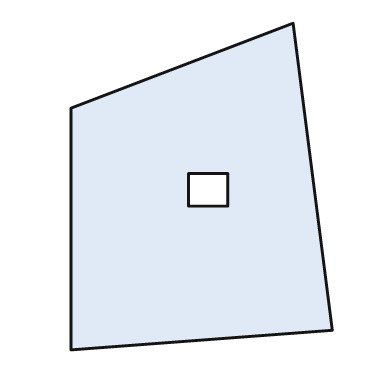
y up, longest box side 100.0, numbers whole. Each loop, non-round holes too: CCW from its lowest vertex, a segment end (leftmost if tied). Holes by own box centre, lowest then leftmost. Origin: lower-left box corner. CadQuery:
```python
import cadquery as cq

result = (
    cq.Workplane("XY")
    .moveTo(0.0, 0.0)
    .lineTo(80.0, 6.0)
    .lineTo(68.0, 100.0)
    .lineTo(0.0, 74.0)
    .close()
    .moveTo(36.0, 44.0)
    .lineTo(48.0, 44.0)
    .lineTo(48.0, 54.0)
    .lineTo(36.0, 54.0)
    .close()
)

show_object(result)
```